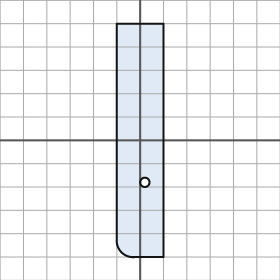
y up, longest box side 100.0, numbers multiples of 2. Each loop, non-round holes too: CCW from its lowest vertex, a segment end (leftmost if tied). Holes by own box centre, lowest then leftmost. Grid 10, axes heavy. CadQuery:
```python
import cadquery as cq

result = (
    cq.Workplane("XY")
    .moveTo(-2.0, -50.0)
    .lineTo(10.0, -50.0)
    .lineTo(10.0, 50.0)
    .lineTo(-10.0, 50.0)
    .lineTo(-10.0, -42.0)
    .threePointArc((-8.0, -48.0), (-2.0, -50.0))
    .close()
    .moveTo(2.0, -18.0)
    .circle(2.0)
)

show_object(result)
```